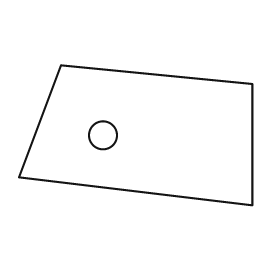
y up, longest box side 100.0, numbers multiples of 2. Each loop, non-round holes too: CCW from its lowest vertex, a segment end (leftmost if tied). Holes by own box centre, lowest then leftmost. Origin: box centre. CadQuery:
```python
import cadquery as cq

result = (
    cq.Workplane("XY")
    .moveTo(50.0, -30.0)
    .lineTo(50.0, 22.0)
    .lineTo(-32.0, 30.0)
    .lineTo(-50.0, -18.0)
    .close()
    .moveTo(-14.0, 0.0)
    .circle(6.0)
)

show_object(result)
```